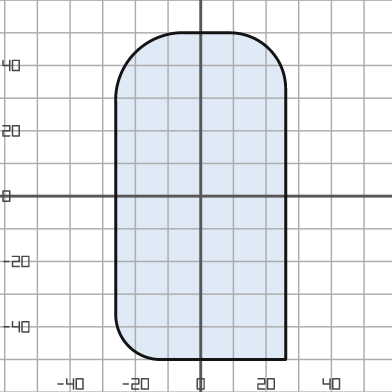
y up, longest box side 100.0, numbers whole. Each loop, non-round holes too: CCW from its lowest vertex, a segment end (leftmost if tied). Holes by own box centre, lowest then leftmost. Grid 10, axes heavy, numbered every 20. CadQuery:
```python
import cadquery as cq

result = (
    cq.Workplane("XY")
    .moveTo(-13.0, -50.0)
    .lineTo(26.0, -50.0)
    .lineTo(26.0, 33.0)
    .threePointArc((21.0, 45.0), (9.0, 50.0))
    .lineTo(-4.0, 50.0)
    .threePointArc((-20.0, 44.0), (-26.0, 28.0))
    .lineTo(-26.0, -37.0)
    .threePointArc((-22.0, -46.0), (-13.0, -50.0))
    .close()
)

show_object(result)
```